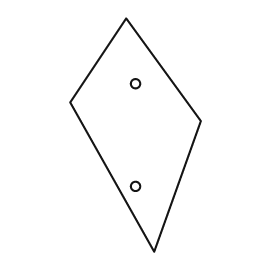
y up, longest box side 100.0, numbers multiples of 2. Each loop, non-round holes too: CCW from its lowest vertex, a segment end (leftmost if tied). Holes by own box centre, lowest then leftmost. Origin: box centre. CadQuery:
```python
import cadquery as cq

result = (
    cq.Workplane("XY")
    .moveTo(8.0, -50.0)
    .lineTo(28.0, 6.0)
    .lineTo(-4.0, 50.0)
    .lineTo(-28.0, 14.0)
    .close()
    .moveTo(0.0, -22.0)
    .circle(2.0)
    .moveTo(0.0, 22.0)
    .circle(2.0)
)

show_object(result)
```